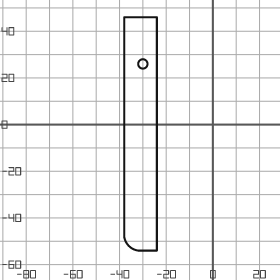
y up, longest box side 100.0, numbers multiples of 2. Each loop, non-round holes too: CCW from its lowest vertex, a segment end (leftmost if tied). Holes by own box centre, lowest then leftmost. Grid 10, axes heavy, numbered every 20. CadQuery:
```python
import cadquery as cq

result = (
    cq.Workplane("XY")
    .moveTo(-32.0, -54.0)
    .lineTo(-24.0, -54.0)
    .lineTo(-24.0, 46.0)
    .lineTo(-38.0, 46.0)
    .lineTo(-38.0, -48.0)
    .threePointArc((-36.0, -52.0), (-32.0, -54.0))
    .close()
    .moveTo(-30.0, 26.0)
    .circle(2.0)
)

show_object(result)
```